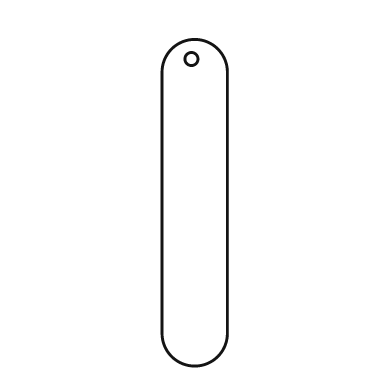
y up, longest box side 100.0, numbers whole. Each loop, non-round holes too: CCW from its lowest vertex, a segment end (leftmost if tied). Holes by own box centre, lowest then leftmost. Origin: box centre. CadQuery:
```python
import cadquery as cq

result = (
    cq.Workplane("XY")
    .moveTo(-10.0, -40.0)
    .threePointArc((0.0, -50.0), (10.0, -40.0))
    .lineTo(10.0, 40.0)
    .threePointArc((0.0, 50.0), (-10.0, 40.0))
    .close()
    .moveTo(-1.0, 44.0)
    .circle(2.0)
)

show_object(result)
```